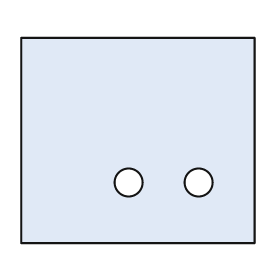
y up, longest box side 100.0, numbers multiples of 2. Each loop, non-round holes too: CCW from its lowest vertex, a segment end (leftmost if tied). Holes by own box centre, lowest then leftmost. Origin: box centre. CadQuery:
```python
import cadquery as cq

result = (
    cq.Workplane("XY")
    .moveTo(-50.0, -44.0)
    .lineTo(50.0, -44.0)
    .lineTo(50.0, 44.0)
    .lineTo(-50.0, 44.0)
    .close()
    .moveTo(-4.0, -18.0)
    .circle(6.0)
    .moveTo(26.0, -18.0)
    .circle(6.0)
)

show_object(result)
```